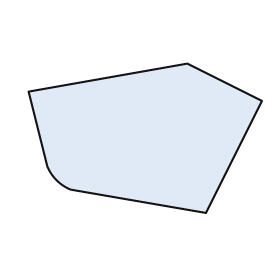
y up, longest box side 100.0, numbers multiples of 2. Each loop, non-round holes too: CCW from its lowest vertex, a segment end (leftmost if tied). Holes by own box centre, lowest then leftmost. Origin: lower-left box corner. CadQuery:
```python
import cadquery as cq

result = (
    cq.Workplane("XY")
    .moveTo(76.0, 0.0)
    .lineTo(100.0, 48.0)
    .lineTo(68.0, 64.0)
    .lineTo(0.0, 52.0)
    .lineTo(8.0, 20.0)
    .threePointArc((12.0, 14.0), (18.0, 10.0))
    .close()
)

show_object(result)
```